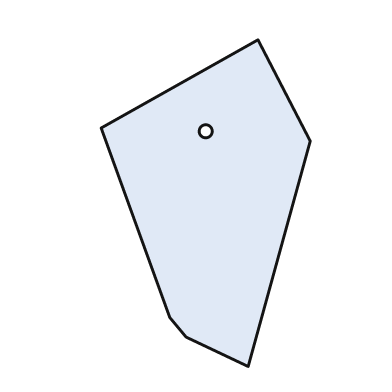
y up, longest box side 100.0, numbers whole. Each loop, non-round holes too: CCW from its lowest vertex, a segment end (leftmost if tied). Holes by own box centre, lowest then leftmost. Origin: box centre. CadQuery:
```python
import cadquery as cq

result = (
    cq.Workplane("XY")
    .moveTo(13.0, -50.0)
    .lineTo(32.0, 19.0)
    .lineTo(16.0, 50.0)
    .lineTo(-32.0, 23.0)
    .lineTo(-11.0, -35.0)
    .lineTo(-6.0, -41.0)
    .close()
    .moveTo(0.0, 22.0)
    .circle(2.0)
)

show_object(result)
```